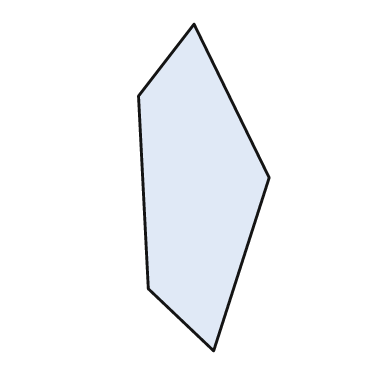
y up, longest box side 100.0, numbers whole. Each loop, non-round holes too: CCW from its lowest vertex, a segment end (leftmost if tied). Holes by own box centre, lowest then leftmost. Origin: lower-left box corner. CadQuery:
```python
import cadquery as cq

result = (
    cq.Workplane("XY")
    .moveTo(23.0, 0.0)
    .lineTo(40.0, 53.0)
    .lineTo(17.0, 100.0)
    .lineTo(0.0, 78.0)
    .lineTo(3.0, 19.0)
    .close()
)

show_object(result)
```